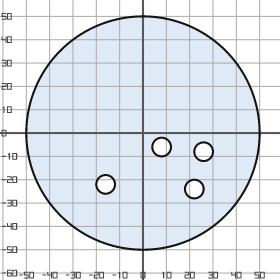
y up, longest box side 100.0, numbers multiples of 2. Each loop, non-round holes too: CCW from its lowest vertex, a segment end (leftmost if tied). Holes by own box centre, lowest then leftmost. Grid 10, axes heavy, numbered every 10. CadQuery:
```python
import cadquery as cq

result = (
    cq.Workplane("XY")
    .moveTo(0.0, 0.0)
    .circle(50.0)
    .moveTo(22.0, -24.0)
    .circle(4.0)
    .moveTo(-16.0, -22.0)
    .circle(4.0)
    .moveTo(26.0, -8.0)
    .circle(4.0)
    .moveTo(8.0, -6.0)
    .circle(4.0)
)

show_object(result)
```